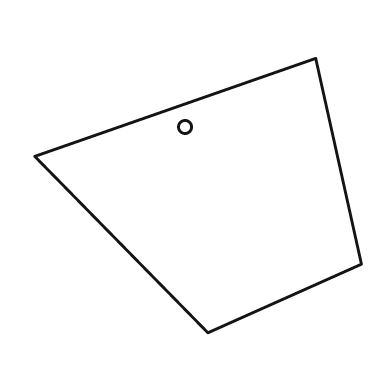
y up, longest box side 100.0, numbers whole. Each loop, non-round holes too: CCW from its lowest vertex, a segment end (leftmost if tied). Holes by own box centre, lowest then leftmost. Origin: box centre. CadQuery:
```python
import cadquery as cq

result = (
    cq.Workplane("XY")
    .moveTo(3.0, -42.0)
    .lineTo(50.0, -21.0)
    .lineTo(36.0, 42.0)
    .lineTo(-50.0, 12.0)
    .close()
    .moveTo(-4.0, 21.0)
    .circle(2.0)
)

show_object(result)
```